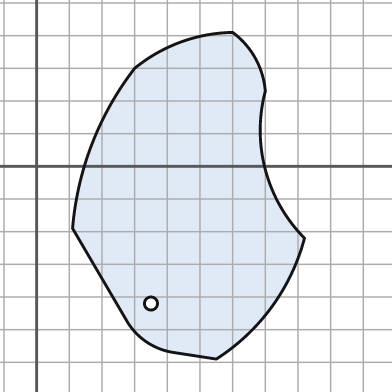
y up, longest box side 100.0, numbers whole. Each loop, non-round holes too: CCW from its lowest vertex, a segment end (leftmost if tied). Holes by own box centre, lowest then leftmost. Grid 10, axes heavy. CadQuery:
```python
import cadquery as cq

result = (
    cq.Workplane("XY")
    .moveTo(55.0, -59.0)
    .threePointArc((72.0, -43.0), (82.0, -22.0))
    .threePointArc((70.0, -1.0), (70.0, 23.0))
    .threePointArc((67.0, 33.0), (60.0, 41.0))
    .threePointArc((44.0, 38.0), (30.0, 30.0))
    .threePointArc((17.0, 7.0), (11.0, -19.0))
    .lineTo(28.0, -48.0)
    .threePointArc((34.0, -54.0), (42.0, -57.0))
    .close()
    .moveTo(35.0, -42.0)
    .circle(2.0)
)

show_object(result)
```